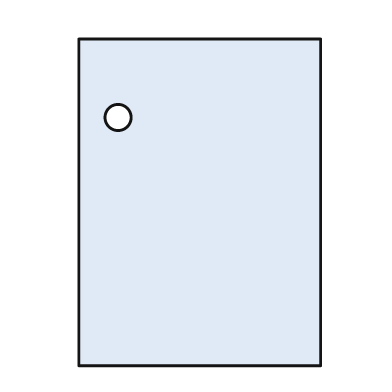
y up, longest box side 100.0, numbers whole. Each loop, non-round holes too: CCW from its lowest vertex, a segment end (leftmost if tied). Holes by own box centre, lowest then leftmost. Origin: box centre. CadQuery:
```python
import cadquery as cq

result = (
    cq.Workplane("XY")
    .moveTo(-37.0, -50.0)
    .lineTo(37.0, -50.0)
    .lineTo(37.0, 50.0)
    .lineTo(-37.0, 50.0)
    .close()
    .moveTo(-25.0, 26.0)
    .circle(4.0)
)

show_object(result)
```